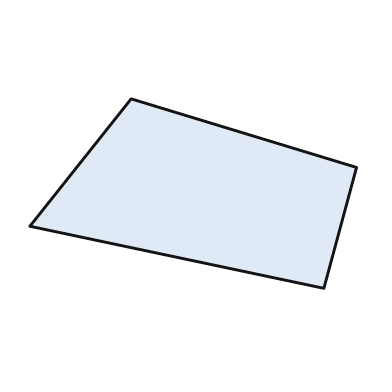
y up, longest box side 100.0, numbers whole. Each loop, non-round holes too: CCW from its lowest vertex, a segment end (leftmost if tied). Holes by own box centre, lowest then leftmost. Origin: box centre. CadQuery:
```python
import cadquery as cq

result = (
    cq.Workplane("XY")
    .moveTo(40.0, -29.0)
    .lineTo(50.0, 8.0)
    .lineTo(-19.0, 29.0)
    .lineTo(-50.0, -10.0)
    .close()
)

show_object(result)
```